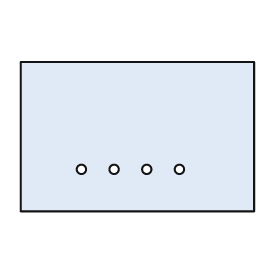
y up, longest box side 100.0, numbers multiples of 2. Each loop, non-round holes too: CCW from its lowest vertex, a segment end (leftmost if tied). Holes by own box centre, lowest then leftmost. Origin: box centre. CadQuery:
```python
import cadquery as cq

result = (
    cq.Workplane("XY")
    .moveTo(-50.0, -32.0)
    .lineTo(50.0, -32.0)
    .lineTo(50.0, 32.0)
    .lineTo(-50.0, 32.0)
    .close()
    .moveTo(-24.0, -14.0)
    .circle(2.0)
    .moveTo(-10.0, -14.0)
    .circle(2.0)
    .moveTo(4.0, -14.0)
    .circle(2.0)
    .moveTo(18.0, -14.0)
    .circle(2.0)
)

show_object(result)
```